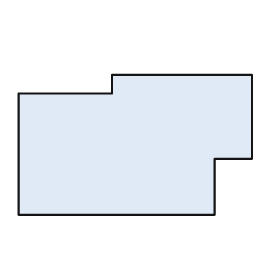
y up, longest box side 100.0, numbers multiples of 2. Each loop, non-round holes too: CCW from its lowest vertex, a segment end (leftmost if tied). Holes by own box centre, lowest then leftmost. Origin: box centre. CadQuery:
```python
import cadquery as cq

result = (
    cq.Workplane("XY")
    .moveTo(-50.0, -30.0)
    .lineTo(34.0, -30.0)
    .lineTo(34.0, -6.0)
    .lineTo(50.0, -6.0)
    .lineTo(50.0, 30.0)
    .lineTo(-10.0, 30.0)
    .lineTo(-10.0, 22.0)
    .lineTo(-50.0, 22.0)
    .close()
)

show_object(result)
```